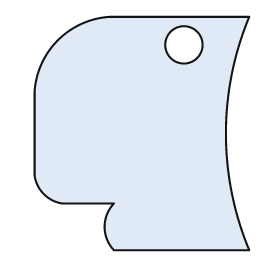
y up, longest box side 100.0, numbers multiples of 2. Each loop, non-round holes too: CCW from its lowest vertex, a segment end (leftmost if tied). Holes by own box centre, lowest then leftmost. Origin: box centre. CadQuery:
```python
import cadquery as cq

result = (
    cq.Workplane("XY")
    .moveTo(-12.0, -50.0)
    .lineTo(46.0, -50.0)
    .threePointArc((36.0, 0.0), (46.0, 50.0))
    .lineTo(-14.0, 50.0)
    .threePointArc((-36.0, 40.0), (-46.0, 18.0))
    .lineTo(-46.0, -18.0)
    .threePointArc((-42.0, -26.0), (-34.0, -30.0))
    .lineTo(-12.0, -30.0)
    .threePointArc((-16.0, -40.0), (-12.0, -50.0))
    .close()
    .moveTo(18.0, 38.0)
    .circle(8.0)
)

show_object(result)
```